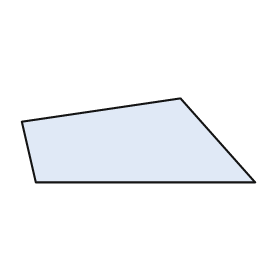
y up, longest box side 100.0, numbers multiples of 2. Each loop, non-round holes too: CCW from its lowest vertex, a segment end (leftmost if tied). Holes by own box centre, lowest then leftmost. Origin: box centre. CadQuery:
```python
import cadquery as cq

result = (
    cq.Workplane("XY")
    .moveTo(-44.0, -18.0)
    .lineTo(50.0, -18.0)
    .lineTo(18.0, 18.0)
    .lineTo(-50.0, 8.0)
    .close()
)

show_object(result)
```